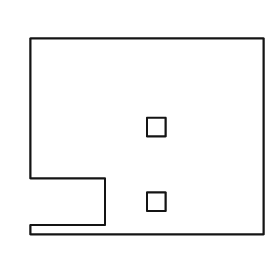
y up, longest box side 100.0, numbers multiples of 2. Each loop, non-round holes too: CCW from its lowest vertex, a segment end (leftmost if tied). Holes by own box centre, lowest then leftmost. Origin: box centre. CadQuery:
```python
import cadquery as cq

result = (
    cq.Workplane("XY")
    .moveTo(-50.0, -42.0)
    .lineTo(50.0, -42.0)
    .lineTo(50.0, 42.0)
    .lineTo(-50.0, 42.0)
    .lineTo(-50.0, -18.0)
    .lineTo(-18.0, -18.0)
    .lineTo(-18.0, -38.0)
    .lineTo(-50.0, -38.0)
    .close()
    .moveTo(0.0, -32.0)
    .lineTo(8.0, -32.0)
    .lineTo(8.0, -24.0)
    .lineTo(0.0, -24.0)
    .close()
    .moveTo(0.0, 0.0)
    .lineTo(8.0, 0.0)
    .lineTo(8.0, 8.0)
    .lineTo(0.0, 8.0)
    .close()
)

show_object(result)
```